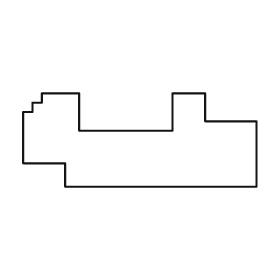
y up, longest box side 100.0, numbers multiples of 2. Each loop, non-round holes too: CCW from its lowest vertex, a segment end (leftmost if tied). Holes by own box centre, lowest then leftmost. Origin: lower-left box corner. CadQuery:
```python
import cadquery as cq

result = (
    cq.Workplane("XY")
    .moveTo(18.0, 0.0)
    .lineTo(100.0, 0.0)
    .lineTo(100.0, 28.0)
    .lineTo(78.0, 28.0)
    .lineTo(78.0, 40.0)
    .lineTo(64.0, 40.0)
    .lineTo(64.0, 24.0)
    .lineTo(24.0, 24.0)
    .lineTo(24.0, 40.0)
    .lineTo(8.0, 40.0)
    .lineTo(8.0, 36.0)
    .lineTo(4.0, 36.0)
    .lineTo(4.0, 32.0)
    .lineTo(0.0, 32.0)
    .lineTo(0.0, 10.0)
    .lineTo(18.0, 10.0)
    .close()
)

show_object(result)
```